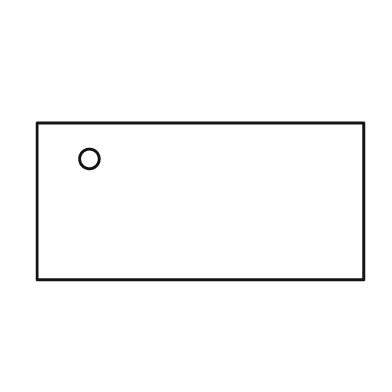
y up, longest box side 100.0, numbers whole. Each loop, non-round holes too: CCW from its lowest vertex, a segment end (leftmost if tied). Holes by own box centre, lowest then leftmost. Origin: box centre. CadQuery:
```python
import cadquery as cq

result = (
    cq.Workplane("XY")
    .moveTo(-50.0, -24.0)
    .lineTo(50.0, -24.0)
    .lineTo(50.0, 24.0)
    .lineTo(-50.0, 24.0)
    .close()
    .moveTo(-34.0, 13.0)
    .circle(3.0)
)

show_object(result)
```